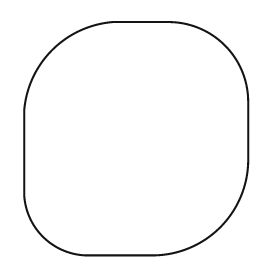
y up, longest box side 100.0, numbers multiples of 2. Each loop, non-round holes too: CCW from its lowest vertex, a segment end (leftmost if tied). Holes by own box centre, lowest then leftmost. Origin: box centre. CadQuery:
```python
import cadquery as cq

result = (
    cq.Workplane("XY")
    .moveTo(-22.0, -50.0)
    .lineTo(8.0, -50.0)
    .threePointArc((36.0, -38.0), (48.0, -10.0))
    .lineTo(48.0, 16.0)
    .threePointArc((38.0, 40.0), (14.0, 50.0))
    .lineTo(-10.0, 50.0)
    .threePointArc((-36.0, 38.0), (-48.0, 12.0))
    .lineTo(-48.0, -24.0)
    .threePointArc((-40.0, -42.0), (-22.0, -50.0))
    .close()
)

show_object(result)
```